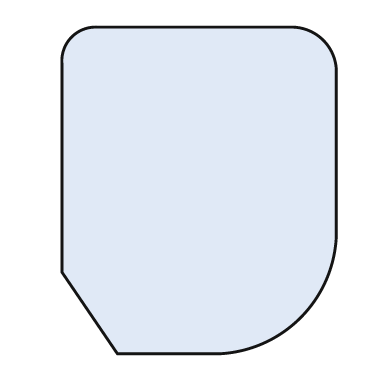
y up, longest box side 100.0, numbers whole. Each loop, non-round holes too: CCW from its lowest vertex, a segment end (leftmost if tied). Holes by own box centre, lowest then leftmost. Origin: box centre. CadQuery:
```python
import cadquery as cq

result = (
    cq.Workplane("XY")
    .moveTo(-25.0, -50.0)
    .lineTo(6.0, -50.0)
    .threePointArc((31.0, -39.0), (42.0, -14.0))
    .lineTo(42.0, 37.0)
    .threePointArc((38.0, 46.0), (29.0, 50.0))
    .lineTo(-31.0, 50.0)
    .threePointArc((-39.0, 47.0), (-42.0, 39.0))
    .lineTo(-42.0, -25.0)
    .close()
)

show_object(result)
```